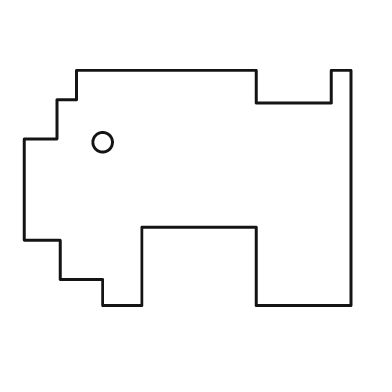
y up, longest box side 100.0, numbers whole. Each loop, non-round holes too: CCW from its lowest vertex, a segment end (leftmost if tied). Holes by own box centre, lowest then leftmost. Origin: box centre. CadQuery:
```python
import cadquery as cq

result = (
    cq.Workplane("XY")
    .moveTo(-26.0, -36.0)
    .lineTo(-14.0, -36.0)
    .lineTo(-14.0, -12.0)
    .lineTo(21.0, -12.0)
    .lineTo(21.0, -36.0)
    .lineTo(50.0, -36.0)
    .lineTo(50.0, 36.0)
    .lineTo(44.0, 36.0)
    .lineTo(44.0, 26.0)
    .lineTo(21.0, 26.0)
    .lineTo(21.0, 36.0)
    .lineTo(-34.0, 36.0)
    .lineTo(-34.0, 27.0)
    .lineTo(-40.0, 27.0)
    .lineTo(-40.0, 15.0)
    .lineTo(-50.0, 15.0)
    .lineTo(-50.0, -16.0)
    .lineTo(-39.0, -16.0)
    .lineTo(-39.0, -28.0)
    .lineTo(-26.0, -28.0)
    .close()
    .moveTo(-26.0, 14.0)
    .circle(3.0)
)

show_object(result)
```